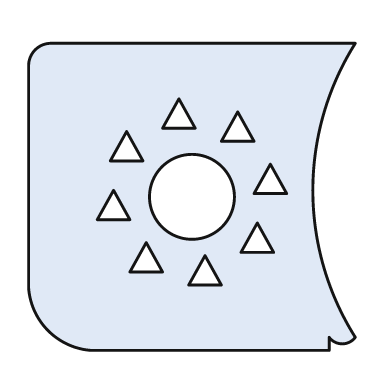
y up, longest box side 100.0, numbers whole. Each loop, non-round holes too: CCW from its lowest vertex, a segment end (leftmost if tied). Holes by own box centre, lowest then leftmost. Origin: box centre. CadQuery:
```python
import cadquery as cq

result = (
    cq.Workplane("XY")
    .moveTo(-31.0, -47.0)
    .lineTo(42.0, -47.0)
    .lineTo(42.0, -43.0)
    .threePointArc((46.0, -45.0), (50.0, -43.0))
    .threePointArc((37.0, 2.0), (50.0, 47.0))
    .lineTo(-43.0, 47.0)
    .threePointArc((-48.0, 45.0), (-50.0, 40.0))
    .lineTo(-50.0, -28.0)
    .threePointArc((-44.0, -41.0), (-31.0, -47.0))
    .close()
    .moveTo(-1.0, -27.0)
    .lineTo(9.0, -27.0)
    .lineTo(4.0, -18.0)
    .close()
    .moveTo(-19.0, -23.0)
    .lineTo(-9.0, -23.0)
    .lineTo(-14.0, -14.0)
    .close()
    .moveTo(15.0, -17.0)
    .lineTo(25.0, -17.0)
    .lineTo(20.0, -8.0)
    .close()
    .moveTo(-29.0, -7.0)
    .lineTo(-19.0, -7.0)
    .lineTo(-24.0, 2.0)
    .close()
    .moveTo(0.0, 0.0)
    .circle(13.0)
    .moveTo(19.0, 1.0)
    .lineTo(29.0, 1.0)
    .lineTo(24.0, 10.0)
    .close()
    .moveTo(-25.0, 11.0)
    .lineTo(-15.0, 11.0)
    .lineTo(-20.0, 20.0)
    .close()
    .moveTo(9.0, 17.0)
    .lineTo(19.0, 17.0)
    .lineTo(14.0, 26.0)
    .close()
    .moveTo(-9.0, 21.0)
    .lineTo(1.0, 21.0)
    .lineTo(-4.0, 30.0)
    .close()
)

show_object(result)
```